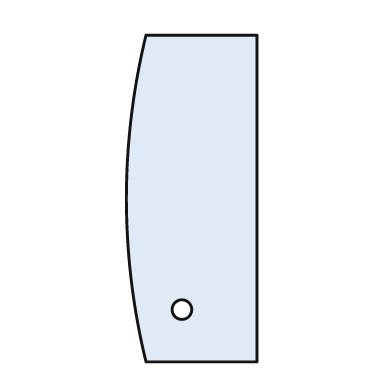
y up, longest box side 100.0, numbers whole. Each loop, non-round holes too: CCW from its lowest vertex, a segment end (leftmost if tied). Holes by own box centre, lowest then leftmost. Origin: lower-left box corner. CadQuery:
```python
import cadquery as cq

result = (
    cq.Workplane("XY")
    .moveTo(6.0, 0.0)
    .lineTo(40.0, 0.0)
    .lineTo(40.0, 100.0)
    .lineTo(6.0, 100.0)
    .threePointArc((0.0, 50.0), (6.0, 0.0))
    .close()
    .moveTo(17.0, 16.0)
    .circle(3.0)
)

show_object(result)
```